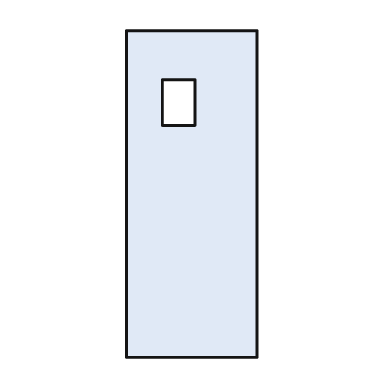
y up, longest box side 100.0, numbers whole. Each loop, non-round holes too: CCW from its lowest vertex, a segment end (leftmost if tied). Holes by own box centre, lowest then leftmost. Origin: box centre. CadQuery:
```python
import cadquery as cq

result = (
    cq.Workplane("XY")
    .moveTo(-20.0, -50.0)
    .lineTo(20.0, -50.0)
    .lineTo(20.0, 50.0)
    .lineTo(-20.0, 50.0)
    .close()
    .moveTo(-9.0, 21.0)
    .lineTo(1.0, 21.0)
    .lineTo(1.0, 35.0)
    .lineTo(-9.0, 35.0)
    .close()
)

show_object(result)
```